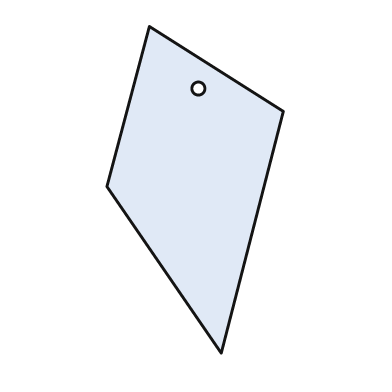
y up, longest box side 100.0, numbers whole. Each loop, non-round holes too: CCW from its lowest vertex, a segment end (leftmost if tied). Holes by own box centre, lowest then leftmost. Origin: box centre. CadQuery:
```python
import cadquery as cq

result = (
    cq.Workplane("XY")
    .moveTo(8.0, -50.0)
    .lineTo(27.0, 24.0)
    .lineTo(-14.0, 50.0)
    .lineTo(-27.0, 1.0)
    .close()
    .moveTo(1.0, 31.0)
    .circle(2.0)
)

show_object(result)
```